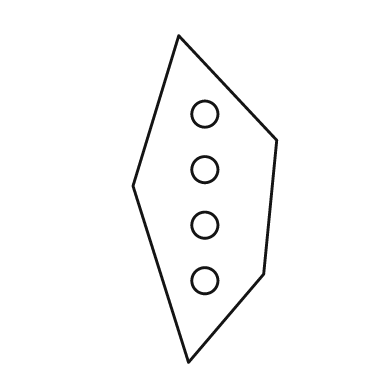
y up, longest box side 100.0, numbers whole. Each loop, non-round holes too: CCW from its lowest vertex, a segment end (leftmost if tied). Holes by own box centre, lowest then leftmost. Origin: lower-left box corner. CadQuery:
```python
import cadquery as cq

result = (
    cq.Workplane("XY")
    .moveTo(17.0, 0.0)
    .lineTo(40.0, 27.0)
    .lineTo(44.0, 68.0)
    .lineTo(14.0, 100.0)
    .lineTo(0.0, 54.0)
    .close()
    .moveTo(22.0, 25.0)
    .circle(4.0)
    .moveTo(22.0, 42.0)
    .circle(4.0)
    .moveTo(22.0, 59.0)
    .circle(4.0)
    .moveTo(22.0, 76.0)
    .circle(4.0)
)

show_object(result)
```